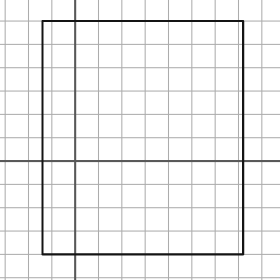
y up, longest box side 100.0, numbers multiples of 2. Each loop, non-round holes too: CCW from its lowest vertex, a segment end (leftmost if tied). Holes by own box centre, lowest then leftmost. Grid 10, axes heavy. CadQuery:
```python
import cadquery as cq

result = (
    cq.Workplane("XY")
    .moveTo(-14.0, -40.0)
    .lineTo(72.0, -40.0)
    .lineTo(72.0, 60.0)
    .lineTo(-14.0, 60.0)
    .close()
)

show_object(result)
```